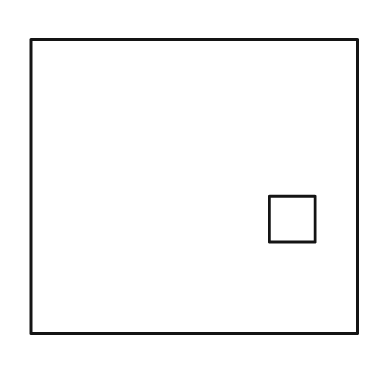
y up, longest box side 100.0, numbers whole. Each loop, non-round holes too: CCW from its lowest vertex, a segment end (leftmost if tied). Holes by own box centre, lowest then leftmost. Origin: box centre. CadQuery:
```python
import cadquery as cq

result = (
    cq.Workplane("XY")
    .moveTo(-50.0, -45.0)
    .lineTo(50.0, -45.0)
    .lineTo(50.0, 45.0)
    .lineTo(-50.0, 45.0)
    .close()
    .moveTo(23.0, -17.0)
    .lineTo(37.0, -17.0)
    .lineTo(37.0, -3.0)
    .lineTo(23.0, -3.0)
    .close()
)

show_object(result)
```